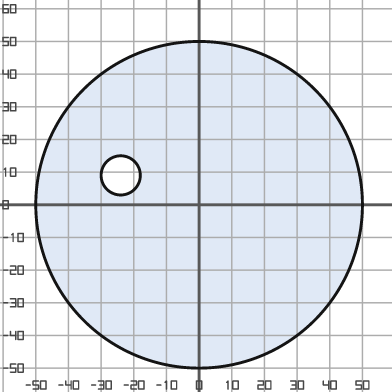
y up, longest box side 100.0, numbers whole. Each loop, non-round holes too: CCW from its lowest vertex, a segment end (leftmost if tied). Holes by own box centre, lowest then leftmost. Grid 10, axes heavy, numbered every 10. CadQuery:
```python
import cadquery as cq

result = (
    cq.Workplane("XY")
    .moveTo(0.0, 0.0)
    .circle(50.0)
    .moveTo(-24.0, 9.0)
    .circle(6.0)
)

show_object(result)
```